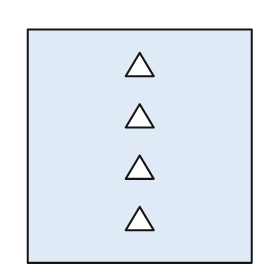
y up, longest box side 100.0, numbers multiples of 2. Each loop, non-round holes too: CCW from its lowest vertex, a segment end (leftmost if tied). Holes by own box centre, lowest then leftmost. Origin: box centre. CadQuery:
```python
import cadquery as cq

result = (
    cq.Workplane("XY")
    .moveTo(-48.0, -50.0)
    .lineTo(48.0, -50.0)
    .lineTo(48.0, 50.0)
    .lineTo(-48.0, 50.0)
    .close()
    .moveTo(-6.0, -36.0)
    .lineTo(6.0, -36.0)
    .lineTo(0.0, -26.0)
    .close()
    .moveTo(-6.0, -14.0)
    .lineTo(6.0, -14.0)
    .lineTo(0.0, -4.0)
    .close()
    .moveTo(-6.0, 8.0)
    .lineTo(6.0, 8.0)
    .lineTo(0.0, 18.0)
    .close()
    .moveTo(-6.0, 30.0)
    .lineTo(6.0, 30.0)
    .lineTo(0.0, 40.0)
    .close()
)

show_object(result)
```